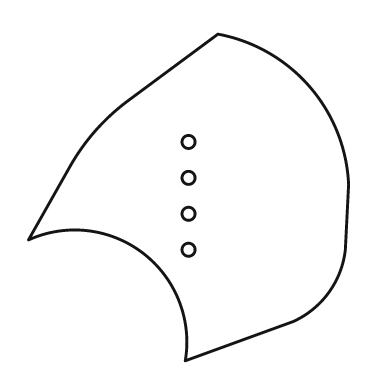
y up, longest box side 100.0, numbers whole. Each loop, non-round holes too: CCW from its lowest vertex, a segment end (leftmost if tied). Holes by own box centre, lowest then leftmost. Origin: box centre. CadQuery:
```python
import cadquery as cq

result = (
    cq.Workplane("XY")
    .moveTo(-1.0, -50.0)
    .lineTo(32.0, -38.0)
    .threePointArc((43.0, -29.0), (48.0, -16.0))
    .lineTo(49.0, 4.0)
    .threePointArc((37.0, 34.0), (9.0, 50.0))
    .lineTo(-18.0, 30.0)
    .threePointArc((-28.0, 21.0), (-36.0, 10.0))
    .lineTo(-49.0, -13.0)
    .threePointArc((-14.0, -17.0), (-1.0, -50.0))
    .close()
    .moveTo(0.0, -16.0)
    .circle(2.0)
    .moveTo(0.0, -5.0)
    .circle(2.0)
    .moveTo(0.0, 6.0)
    .circle(2.0)
    .moveTo(0.0, 17.0)
    .circle(2.0)
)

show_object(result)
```